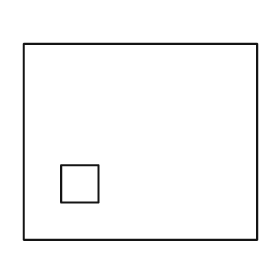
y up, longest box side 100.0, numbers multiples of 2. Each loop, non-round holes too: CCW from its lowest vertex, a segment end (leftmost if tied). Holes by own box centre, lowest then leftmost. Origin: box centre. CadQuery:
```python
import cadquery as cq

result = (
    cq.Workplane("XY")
    .moveTo(-50.0, -42.0)
    .lineTo(50.0, -42.0)
    .lineTo(50.0, 42.0)
    .lineTo(-50.0, 42.0)
    .close()
    .moveTo(-34.0, -26.0)
    .lineTo(-18.0, -26.0)
    .lineTo(-18.0, -10.0)
    .lineTo(-34.0, -10.0)
    .close()
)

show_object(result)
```